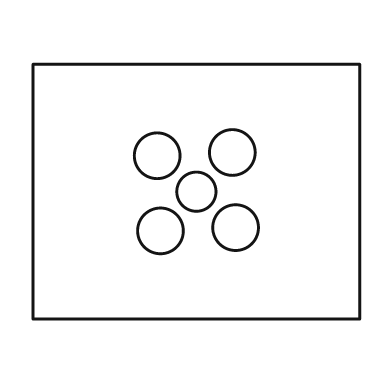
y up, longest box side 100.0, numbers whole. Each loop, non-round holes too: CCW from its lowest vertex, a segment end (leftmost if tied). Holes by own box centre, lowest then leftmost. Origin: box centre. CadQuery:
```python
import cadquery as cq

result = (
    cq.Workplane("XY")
    .moveTo(-50.0, -39.0)
    .lineTo(50.0, -39.0)
    .lineTo(50.0, 39.0)
    .lineTo(-50.0, 39.0)
    .close()
    .moveTo(-11.0, -12.0)
    .circle(7.0)
    .moveTo(12.0, -11.0)
    .circle(7.0)
    .moveTo(0.0, 0.0)
    .circle(6.0)
    .moveTo(-12.0, 11.0)
    .circle(7.0)
    .moveTo(11.0, 12.0)
    .circle(7.0)
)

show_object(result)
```